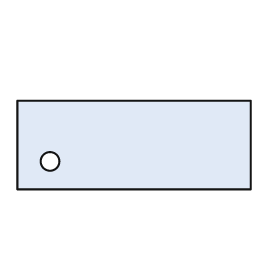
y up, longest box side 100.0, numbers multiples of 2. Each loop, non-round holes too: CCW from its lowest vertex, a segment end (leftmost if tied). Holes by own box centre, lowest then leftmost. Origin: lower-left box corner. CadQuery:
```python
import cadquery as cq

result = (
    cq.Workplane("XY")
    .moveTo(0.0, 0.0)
    .lineTo(100.0, 0.0)
    .lineTo(100.0, 38.0)
    .lineTo(0.0, 38.0)
    .close()
    .moveTo(14.0, 12.0)
    .circle(4.0)
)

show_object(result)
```